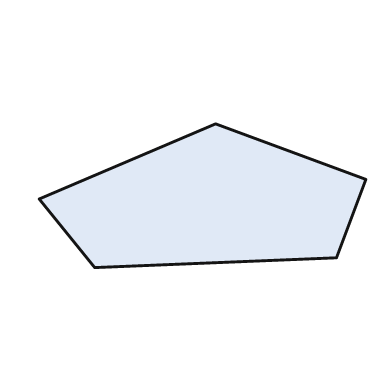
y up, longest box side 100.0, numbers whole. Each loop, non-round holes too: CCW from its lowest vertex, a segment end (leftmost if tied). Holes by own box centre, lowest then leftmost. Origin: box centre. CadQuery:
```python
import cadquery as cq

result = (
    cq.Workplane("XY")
    .moveTo(-33.0, -22.0)
    .lineTo(41.0, -19.0)
    .lineTo(50.0, 5.0)
    .lineTo(4.0, 22.0)
    .lineTo(-50.0, -1.0)
    .close()
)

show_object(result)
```